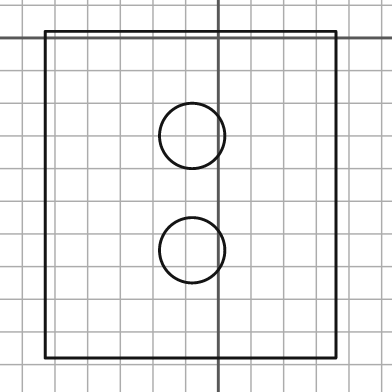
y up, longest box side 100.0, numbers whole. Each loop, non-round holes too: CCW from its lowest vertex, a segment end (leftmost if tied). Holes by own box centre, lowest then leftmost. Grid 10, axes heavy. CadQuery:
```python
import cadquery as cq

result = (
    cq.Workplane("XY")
    .moveTo(-53.0, -98.0)
    .lineTo(36.0, -98.0)
    .lineTo(36.0, 2.0)
    .lineTo(-53.0, 2.0)
    .close()
    .moveTo(-8.0, -65.0)
    .circle(10.0)
    .moveTo(-8.0, -30.0)
    .circle(10.0)
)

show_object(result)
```